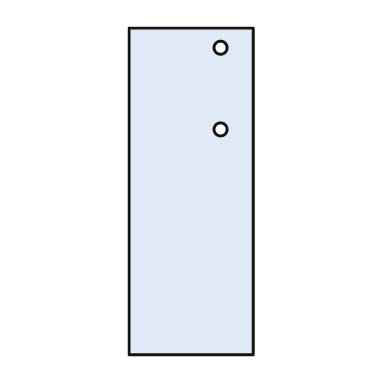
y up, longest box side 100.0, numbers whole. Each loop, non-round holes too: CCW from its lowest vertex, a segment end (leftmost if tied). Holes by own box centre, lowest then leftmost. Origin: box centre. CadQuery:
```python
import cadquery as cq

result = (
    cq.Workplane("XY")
    .moveTo(-19.0, -50.0)
    .lineTo(19.0, -50.0)
    .lineTo(19.0, 50.0)
    .lineTo(-19.0, 50.0)
    .close()
    .moveTo(9.0, 19.0)
    .circle(2.0)
    .moveTo(9.0, 44.0)
    .circle(2.0)
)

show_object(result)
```